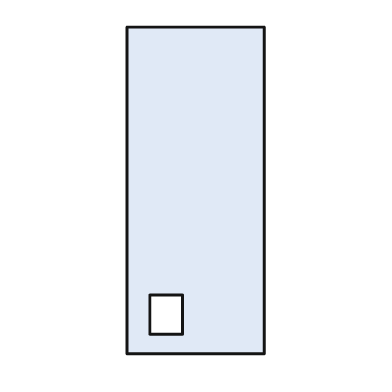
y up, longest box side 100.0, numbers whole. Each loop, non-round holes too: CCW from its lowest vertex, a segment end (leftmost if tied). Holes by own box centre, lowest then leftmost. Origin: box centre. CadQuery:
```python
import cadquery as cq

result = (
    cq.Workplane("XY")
    .moveTo(-21.0, -50.0)
    .lineTo(21.0, -50.0)
    .lineTo(21.0, 50.0)
    .lineTo(-21.0, 50.0)
    .close()
    .moveTo(-14.0, -44.0)
    .lineTo(-4.0, -44.0)
    .lineTo(-4.0, -32.0)
    .lineTo(-14.0, -32.0)
    .close()
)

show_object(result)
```